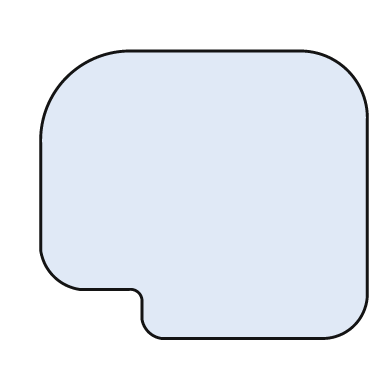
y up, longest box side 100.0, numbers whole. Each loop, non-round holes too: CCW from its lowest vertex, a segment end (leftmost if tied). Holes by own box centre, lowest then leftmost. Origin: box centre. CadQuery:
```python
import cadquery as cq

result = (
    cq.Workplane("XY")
    .moveTo(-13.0, -44.0)
    .lineTo(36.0, -44.0)
    .threePointArc((46.0, -40.0), (50.0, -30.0))
    .lineTo(50.0, 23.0)
    .threePointArc((44.0, 38.0), (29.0, 44.0))
    .lineTo(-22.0, 44.0)
    .threePointArc((-42.0, 36.0), (-50.0, 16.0))
    .lineTo(-50.0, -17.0)
    .threePointArc((-46.0, -25.0), (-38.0, -29.0))
    .lineTo(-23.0, -29.0)
    .threePointArc((-20.0, -30.0), (-19.0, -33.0))
    .lineTo(-19.0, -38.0)
    .threePointArc((-17.0, -42.0), (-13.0, -44.0))
    .close()
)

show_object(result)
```